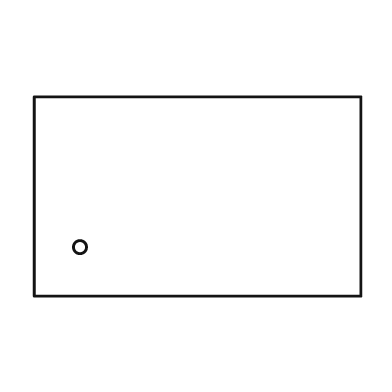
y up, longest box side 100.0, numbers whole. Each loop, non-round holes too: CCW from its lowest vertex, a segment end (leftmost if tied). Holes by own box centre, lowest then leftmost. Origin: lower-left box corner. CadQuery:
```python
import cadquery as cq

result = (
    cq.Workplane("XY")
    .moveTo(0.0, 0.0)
    .lineTo(100.0, 0.0)
    .lineTo(100.0, 61.0)
    .lineTo(0.0, 61.0)
    .close()
    .moveTo(14.0, 15.0)
    .circle(2.0)
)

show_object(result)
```